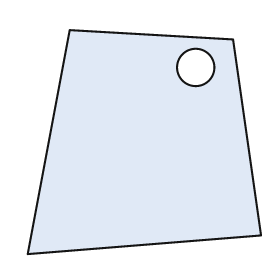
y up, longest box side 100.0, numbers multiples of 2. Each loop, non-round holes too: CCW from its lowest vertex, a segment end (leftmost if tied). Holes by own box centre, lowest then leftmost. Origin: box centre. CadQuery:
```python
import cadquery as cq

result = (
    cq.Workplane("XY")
    .moveTo(-50.0, -48.0)
    .lineTo(50.0, -40.0)
    .lineTo(38.0, 44.0)
    .lineTo(-32.0, 48.0)
    .close()
    .moveTo(22.0, 32.0)
    .circle(8.0)
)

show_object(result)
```